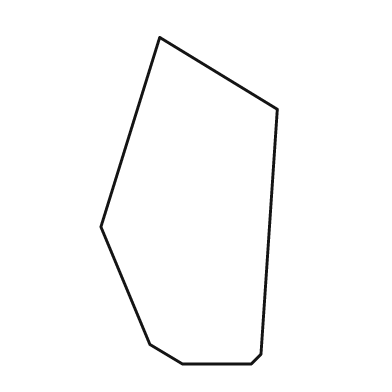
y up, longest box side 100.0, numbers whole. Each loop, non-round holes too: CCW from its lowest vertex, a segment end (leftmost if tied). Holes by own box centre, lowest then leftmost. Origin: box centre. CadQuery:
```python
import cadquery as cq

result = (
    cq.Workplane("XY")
    .moveTo(-2.0, -50.0)
    .lineTo(19.0, -50.0)
    .lineTo(22.0, -47.0)
    .lineTo(27.0, 28.0)
    .lineTo(-9.0, 50.0)
    .lineTo(-27.0, -8.0)
    .lineTo(-12.0, -44.0)
    .close()
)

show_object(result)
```